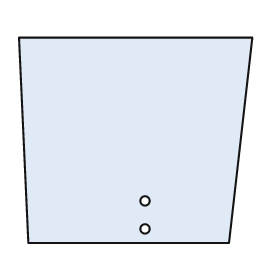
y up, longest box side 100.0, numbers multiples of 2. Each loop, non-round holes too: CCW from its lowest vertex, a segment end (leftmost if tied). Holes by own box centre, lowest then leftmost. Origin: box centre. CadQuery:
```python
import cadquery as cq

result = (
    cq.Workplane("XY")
    .moveTo(-46.0, -44.0)
    .lineTo(40.0, -44.0)
    .lineTo(50.0, 44.0)
    .lineTo(-50.0, 44.0)
    .close()
    .moveTo(4.0, -38.0)
    .circle(2.0)
    .moveTo(4.0, -26.0)
    .circle(2.0)
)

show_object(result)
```